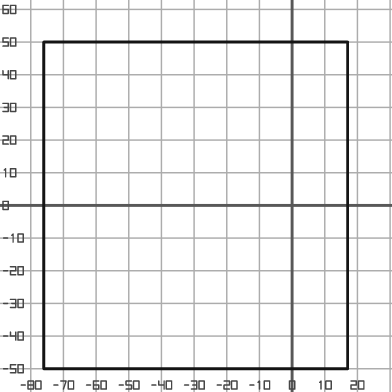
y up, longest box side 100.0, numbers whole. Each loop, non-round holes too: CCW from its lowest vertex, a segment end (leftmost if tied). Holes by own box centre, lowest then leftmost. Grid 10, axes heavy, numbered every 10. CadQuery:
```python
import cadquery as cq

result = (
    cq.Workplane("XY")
    .moveTo(-76.0, -50.0)
    .lineTo(17.0, -50.0)
    .lineTo(17.0, 50.0)
    .lineTo(-76.0, 50.0)
    .close()
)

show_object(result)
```